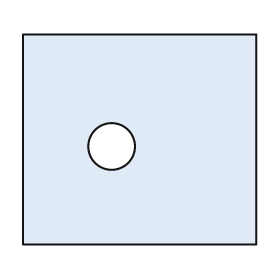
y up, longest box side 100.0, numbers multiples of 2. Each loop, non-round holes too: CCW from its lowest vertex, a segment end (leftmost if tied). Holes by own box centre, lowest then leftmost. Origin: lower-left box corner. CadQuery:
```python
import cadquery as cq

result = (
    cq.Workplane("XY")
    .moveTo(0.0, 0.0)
    .lineTo(100.0, 0.0)
    .lineTo(100.0, 90.0)
    .lineTo(0.0, 90.0)
    .close()
    .moveTo(38.0, 42.0)
    .circle(10.0)
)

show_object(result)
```